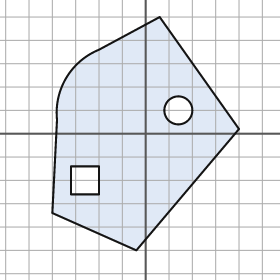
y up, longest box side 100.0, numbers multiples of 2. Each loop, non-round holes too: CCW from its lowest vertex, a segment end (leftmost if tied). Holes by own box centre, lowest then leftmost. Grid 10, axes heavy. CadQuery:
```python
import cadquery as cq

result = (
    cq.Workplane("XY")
    .moveTo(-4.0, -50.0)
    .lineTo(40.0, 2.0)
    .lineTo(6.0, 50.0)
    .lineTo(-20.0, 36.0)
    .threePointArc((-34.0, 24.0), (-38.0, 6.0))
    .lineTo(-40.0, -34.0)
    .close()
    .moveTo(-32.0, -26.0)
    .lineTo(-20.0, -26.0)
    .lineTo(-20.0, -14.0)
    .lineTo(-32.0, -14.0)
    .close()
    .moveTo(14.0, 10.0)
    .circle(6.0)
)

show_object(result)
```